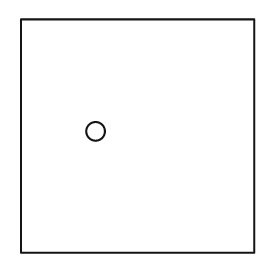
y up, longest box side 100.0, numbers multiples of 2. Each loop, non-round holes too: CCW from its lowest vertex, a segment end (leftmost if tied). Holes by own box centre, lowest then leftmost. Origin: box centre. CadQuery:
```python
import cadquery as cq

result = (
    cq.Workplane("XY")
    .moveTo(-50.0, -50.0)
    .lineTo(50.0, -50.0)
    .lineTo(50.0, 50.0)
    .lineTo(-50.0, 50.0)
    .close()
    .moveTo(-18.0, 2.0)
    .circle(4.0)
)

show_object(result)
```